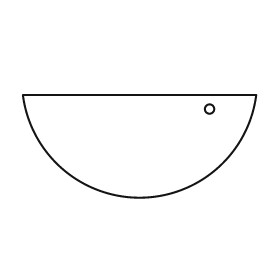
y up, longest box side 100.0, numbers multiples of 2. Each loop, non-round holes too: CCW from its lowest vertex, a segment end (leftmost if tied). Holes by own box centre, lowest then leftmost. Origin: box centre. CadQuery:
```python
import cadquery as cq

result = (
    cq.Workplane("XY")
    .moveTo(-50.0, 22.0)
    .threePointArc((0.0, -22.0), (50.0, 22.0))
    .close()
    .moveTo(30.0, 16.0)
    .circle(2.0)
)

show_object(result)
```